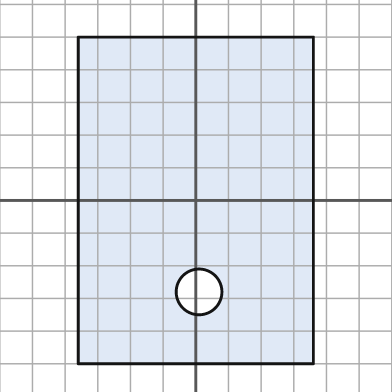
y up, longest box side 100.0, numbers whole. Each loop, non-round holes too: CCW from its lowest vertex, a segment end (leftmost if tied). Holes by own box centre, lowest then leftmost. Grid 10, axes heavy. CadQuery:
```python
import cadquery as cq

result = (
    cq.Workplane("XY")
    .moveTo(-36.0, -50.0)
    .lineTo(36.0, -50.0)
    .lineTo(36.0, 50.0)
    .lineTo(-36.0, 50.0)
    .close()
    .moveTo(1.0, -28.0)
    .circle(7.0)
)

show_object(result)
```